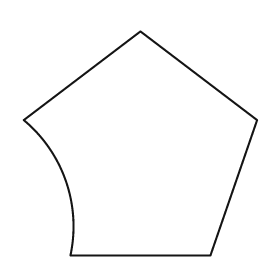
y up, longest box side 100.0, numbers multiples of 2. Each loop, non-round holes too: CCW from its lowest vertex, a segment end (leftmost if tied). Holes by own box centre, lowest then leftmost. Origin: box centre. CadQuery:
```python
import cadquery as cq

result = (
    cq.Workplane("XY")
    .moveTo(-30.0, -48.0)
    .lineTo(30.0, -48.0)
    .lineTo(50.0, 10.0)
    .lineTo(0.0, 48.0)
    .lineTo(-50.0, 10.0)
    .threePointArc((-32.0, -16.0), (-30.0, -48.0))
    .close()
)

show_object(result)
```